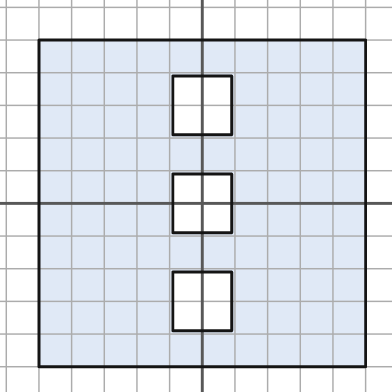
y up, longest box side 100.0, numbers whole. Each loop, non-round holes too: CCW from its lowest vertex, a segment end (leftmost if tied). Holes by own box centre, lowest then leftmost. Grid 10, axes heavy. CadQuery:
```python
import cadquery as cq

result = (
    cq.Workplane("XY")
    .moveTo(-50.0, -50.0)
    .lineTo(50.0, -50.0)
    .lineTo(50.0, 50.0)
    .lineTo(-50.0, 50.0)
    .close()
    .moveTo(-9.0, -39.0)
    .lineTo(9.0, -39.0)
    .lineTo(9.0, -21.0)
    .lineTo(-9.0, -21.0)
    .close()
    .moveTo(-9.0, -9.0)
    .lineTo(9.0, -9.0)
    .lineTo(9.0, 9.0)
    .lineTo(-9.0, 9.0)
    .close()
    .moveTo(-9.0, 21.0)
    .lineTo(9.0, 21.0)
    .lineTo(9.0, 39.0)
    .lineTo(-9.0, 39.0)
    .close()
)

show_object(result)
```